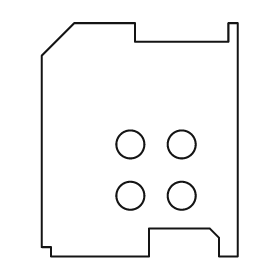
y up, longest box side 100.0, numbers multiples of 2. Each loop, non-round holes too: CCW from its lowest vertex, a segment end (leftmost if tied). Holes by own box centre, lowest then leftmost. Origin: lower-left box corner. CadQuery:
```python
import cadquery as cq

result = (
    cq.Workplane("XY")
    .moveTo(4.0, 0.0)
    .lineTo(46.0, 0.0)
    .lineTo(46.0, 12.0)
    .lineTo(72.0, 12.0)
    .lineTo(76.0, 8.0)
    .lineTo(76.0, 0.0)
    .lineTo(84.0, 0.0)
    .lineTo(84.0, 100.0)
    .lineTo(80.0, 100.0)
    .lineTo(80.0, 92.0)
    .lineTo(40.0, 92.0)
    .lineTo(40.0, 100.0)
    .lineTo(14.0, 100.0)
    .lineTo(0.0, 86.0)
    .lineTo(0.0, 4.0)
    .lineTo(4.0, 4.0)
    .close()
    .moveTo(38.0, 26.0)
    .circle(6.0)
    .moveTo(60.0, 26.0)
    .circle(6.0)
    .moveTo(38.0, 48.0)
    .circle(6.0)
    .moveTo(60.0, 48.0)
    .circle(6.0)
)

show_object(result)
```